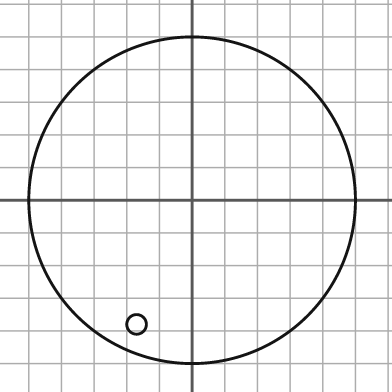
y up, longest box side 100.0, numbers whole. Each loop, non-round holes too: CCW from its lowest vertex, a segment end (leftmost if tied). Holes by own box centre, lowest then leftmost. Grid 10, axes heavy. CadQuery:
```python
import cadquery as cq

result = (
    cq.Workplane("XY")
    .moveTo(0.0, 0.0)
    .circle(50.0)
    .moveTo(-17.0, -38.0)
    .circle(3.0)
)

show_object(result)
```